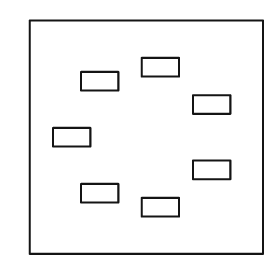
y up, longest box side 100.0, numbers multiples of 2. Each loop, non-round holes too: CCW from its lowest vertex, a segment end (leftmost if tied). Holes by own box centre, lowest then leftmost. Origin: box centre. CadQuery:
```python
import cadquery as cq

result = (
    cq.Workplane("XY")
    .moveTo(-50.0, -50.0)
    .lineTo(50.0, -50.0)
    .lineTo(50.0, 50.0)
    .lineTo(-50.0, 50.0)
    .close()
    .moveTo(-2.0, -34.0)
    .lineTo(14.0, -34.0)
    .lineTo(14.0, -26.0)
    .lineTo(-2.0, -26.0)
    .close()
    .moveTo(-28.0, -28.0)
    .lineTo(-12.0, -28.0)
    .lineTo(-12.0, -20.0)
    .lineTo(-28.0, -20.0)
    .close()
    .moveTo(20.0, -18.0)
    .lineTo(36.0, -18.0)
    .lineTo(36.0, -10.0)
    .lineTo(20.0, -10.0)
    .close()
    .moveTo(-40.0, -4.0)
    .lineTo(-24.0, -4.0)
    .lineTo(-24.0, 4.0)
    .lineTo(-40.0, 4.0)
    .close()
    .moveTo(20.0, 10.0)
    .lineTo(36.0, 10.0)
    .lineTo(36.0, 18.0)
    .lineTo(20.0, 18.0)
    .close()
    .moveTo(-28.0, 20.0)
    .lineTo(-12.0, 20.0)
    .lineTo(-12.0, 28.0)
    .lineTo(-28.0, 28.0)
    .close()
    .moveTo(-2.0, 26.0)
    .lineTo(14.0, 26.0)
    .lineTo(14.0, 34.0)
    .lineTo(-2.0, 34.0)
    .close()
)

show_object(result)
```